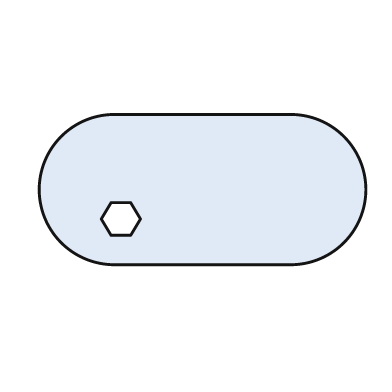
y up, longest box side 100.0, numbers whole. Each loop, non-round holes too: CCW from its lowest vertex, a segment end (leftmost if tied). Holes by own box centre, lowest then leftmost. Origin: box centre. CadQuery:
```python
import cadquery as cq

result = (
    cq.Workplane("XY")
    .moveTo(-27.0, -23.0)
    .lineTo(27.0, -23.0)
    .threePointArc((50.0, 0.0), (27.0, 23.0))
    .lineTo(-27.0, 23.0)
    .threePointArc((-50.0, 0.0), (-27.0, -23.0))
    .close()
    .moveTo(-28.0, -14.0)
    .lineTo(-22.0, -14.0)
    .lineTo(-19.0, -9.0)
    .lineTo(-22.0, -4.0)
    .lineTo(-28.0, -4.0)
    .lineTo(-31.0, -9.0)
    .close()
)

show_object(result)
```